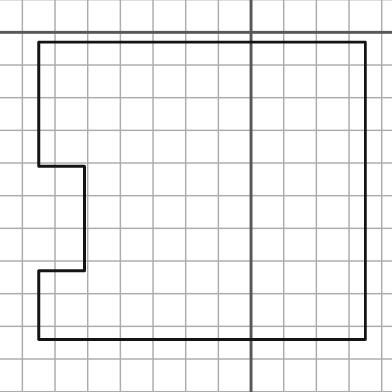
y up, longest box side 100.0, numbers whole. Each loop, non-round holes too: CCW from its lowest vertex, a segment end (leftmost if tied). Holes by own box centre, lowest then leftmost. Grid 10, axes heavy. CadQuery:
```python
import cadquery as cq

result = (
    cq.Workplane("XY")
    .moveTo(-65.0, -94.0)
    .lineTo(35.0, -94.0)
    .lineTo(35.0, -3.0)
    .lineTo(-65.0, -3.0)
    .lineTo(-65.0, -41.0)
    .lineTo(-51.0, -41.0)
    .lineTo(-51.0, -73.0)
    .lineTo(-65.0, -73.0)
    .close()
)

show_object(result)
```